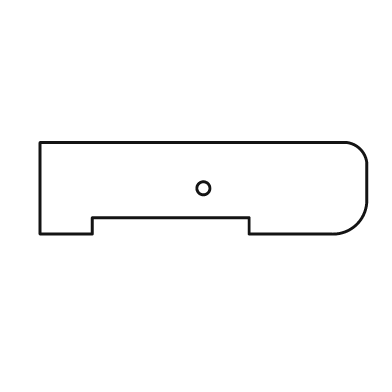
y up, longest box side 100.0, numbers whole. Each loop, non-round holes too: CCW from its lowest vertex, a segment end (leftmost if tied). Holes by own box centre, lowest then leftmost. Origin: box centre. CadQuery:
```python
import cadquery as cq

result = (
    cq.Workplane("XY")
    .moveTo(-50.0, -14.0)
    .lineTo(-34.0, -14.0)
    .lineTo(-34.0, -9.0)
    .lineTo(14.0, -9.0)
    .lineTo(14.0, -14.0)
    .lineTo(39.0, -14.0)
    .threePointArc((47.0, -11.0), (50.0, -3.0))
    .lineTo(50.0, 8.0)
    .threePointArc((48.0, 12.0), (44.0, 14.0))
    .lineTo(-50.0, 14.0)
    .close()
    .moveTo(0.0, 0.0)
    .circle(2.0)
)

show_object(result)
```